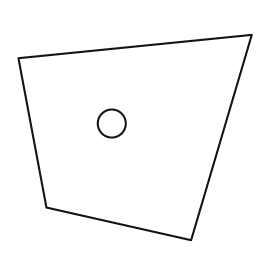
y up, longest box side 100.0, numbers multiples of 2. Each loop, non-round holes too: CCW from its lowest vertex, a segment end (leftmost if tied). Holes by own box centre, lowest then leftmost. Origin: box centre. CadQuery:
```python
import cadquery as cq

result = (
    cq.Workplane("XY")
    .moveTo(24.0, -44.0)
    .lineTo(50.0, 44.0)
    .lineTo(-50.0, 34.0)
    .lineTo(-38.0, -30.0)
    .close()
    .moveTo(-10.0, 6.0)
    .circle(6.0)
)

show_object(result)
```